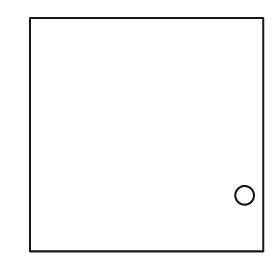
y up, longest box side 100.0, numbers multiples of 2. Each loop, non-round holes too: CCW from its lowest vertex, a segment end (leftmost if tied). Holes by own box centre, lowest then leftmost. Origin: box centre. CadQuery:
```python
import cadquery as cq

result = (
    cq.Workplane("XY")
    .moveTo(-50.0, -50.0)
    .lineTo(50.0, -50.0)
    .lineTo(50.0, 50.0)
    .lineTo(-50.0, 50.0)
    .close()
    .moveTo(42.0, -26.0)
    .circle(4.0)
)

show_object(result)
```